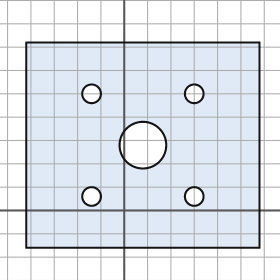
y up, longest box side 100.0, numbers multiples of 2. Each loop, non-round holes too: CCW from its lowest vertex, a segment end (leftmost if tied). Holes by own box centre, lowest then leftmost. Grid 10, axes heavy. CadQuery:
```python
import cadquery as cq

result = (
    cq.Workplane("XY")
    .moveTo(-42.0, -16.0)
    .lineTo(58.0, -16.0)
    .lineTo(58.0, 72.0)
    .lineTo(-42.0, 72.0)
    .close()
    .moveTo(-14.0, 6.0)
    .circle(4.0)
    .moveTo(30.0, 6.0)
    .circle(4.0)
    .moveTo(8.0, 28.0)
    .circle(10.0)
    .moveTo(-14.0, 50.0)
    .circle(4.0)
    .moveTo(30.0, 50.0)
    .circle(4.0)
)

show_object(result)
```